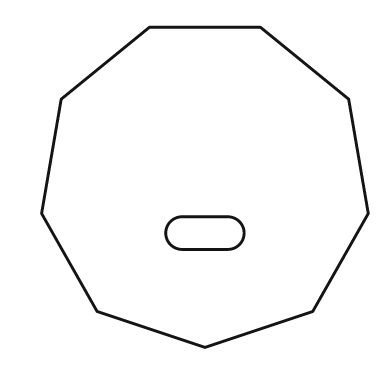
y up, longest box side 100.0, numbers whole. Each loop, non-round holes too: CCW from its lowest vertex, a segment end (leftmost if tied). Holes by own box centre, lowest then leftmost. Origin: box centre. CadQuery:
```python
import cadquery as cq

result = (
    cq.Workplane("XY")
    .moveTo(0.0, -49.0)
    .lineTo(33.0, -38.0)
    .lineTo(50.0, -8.0)
    .lineTo(44.0, 27.0)
    .lineTo(17.0, 49.0)
    .lineTo(-17.0, 49.0)
    .lineTo(-44.0, 27.0)
    .lineTo(-50.0, -8.0)
    .lineTo(-33.0, -38.0)
    .close()
    .moveTo(-7.0, -19.0)
    .lineTo(7.0, -19.0)
    .threePointArc((12.0, -14.0), (7.0, -9.0))
    .lineTo(-7.0, -9.0)
    .threePointArc((-12.0, -14.0), (-7.0, -19.0))
    .close()
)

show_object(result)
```